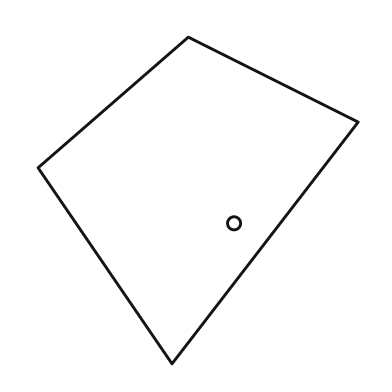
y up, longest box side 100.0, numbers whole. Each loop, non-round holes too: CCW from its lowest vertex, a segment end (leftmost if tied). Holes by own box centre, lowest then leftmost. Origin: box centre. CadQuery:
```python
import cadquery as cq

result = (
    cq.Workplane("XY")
    .moveTo(-8.0, -50.0)
    .lineTo(49.0, 24.0)
    .lineTo(-3.0, 50.0)
    .lineTo(-49.0, 10.0)
    .close()
    .moveTo(11.0, -7.0)
    .circle(2.0)
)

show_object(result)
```